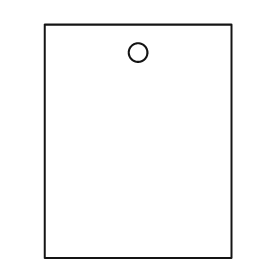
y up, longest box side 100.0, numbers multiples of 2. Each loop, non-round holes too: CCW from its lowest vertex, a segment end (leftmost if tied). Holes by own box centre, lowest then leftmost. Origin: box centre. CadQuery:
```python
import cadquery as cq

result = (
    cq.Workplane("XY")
    .moveTo(-40.0, -50.0)
    .lineTo(40.0, -50.0)
    .lineTo(40.0, 50.0)
    .lineTo(-40.0, 50.0)
    .close()
    .moveTo(0.0, 38.0)
    .circle(4.0)
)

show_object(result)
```